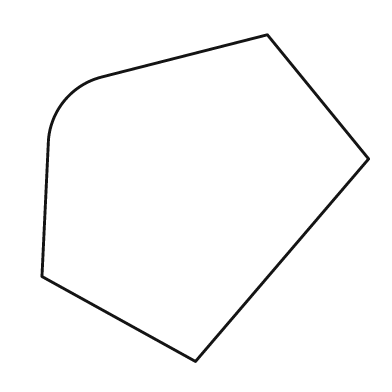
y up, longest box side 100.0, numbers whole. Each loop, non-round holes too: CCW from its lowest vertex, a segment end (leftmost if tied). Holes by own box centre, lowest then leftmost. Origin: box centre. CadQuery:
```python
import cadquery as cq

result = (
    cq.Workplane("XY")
    .moveTo(-3.0, -50.0)
    .lineTo(50.0, 12.0)
    .lineTo(19.0, 50.0)
    .lineTo(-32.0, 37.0)
    .threePointArc((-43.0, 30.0), (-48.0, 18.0))
    .lineTo(-50.0, -24.0)
    .close()
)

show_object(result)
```